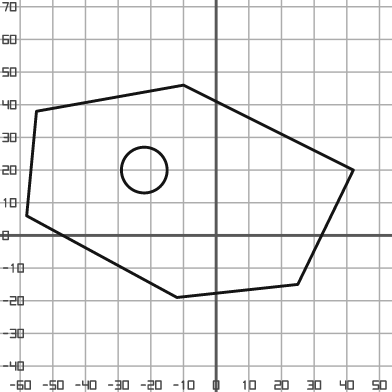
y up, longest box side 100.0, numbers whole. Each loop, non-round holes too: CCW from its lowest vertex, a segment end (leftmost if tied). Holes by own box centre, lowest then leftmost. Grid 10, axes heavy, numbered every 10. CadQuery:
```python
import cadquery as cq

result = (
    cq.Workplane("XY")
    .moveTo(-12.0, -19.0)
    .lineTo(25.0, -15.0)
    .lineTo(42.0, 20.0)
    .lineTo(-10.0, 46.0)
    .lineTo(-55.0, 38.0)
    .lineTo(-58.0, 6.0)
    .close()
    .moveTo(-22.0, 20.0)
    .circle(7.0)
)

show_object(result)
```